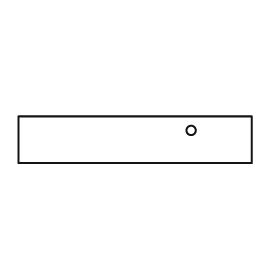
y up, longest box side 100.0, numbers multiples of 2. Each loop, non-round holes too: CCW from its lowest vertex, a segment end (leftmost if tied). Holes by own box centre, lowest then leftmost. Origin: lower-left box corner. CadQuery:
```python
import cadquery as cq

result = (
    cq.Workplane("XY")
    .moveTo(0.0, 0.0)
    .lineTo(100.0, 0.0)
    .lineTo(100.0, 20.0)
    .lineTo(0.0, 20.0)
    .close()
    .moveTo(74.0, 14.0)
    .circle(2.0)
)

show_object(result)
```